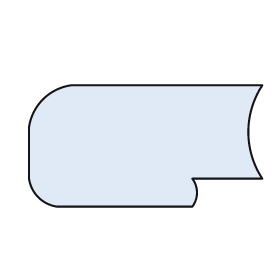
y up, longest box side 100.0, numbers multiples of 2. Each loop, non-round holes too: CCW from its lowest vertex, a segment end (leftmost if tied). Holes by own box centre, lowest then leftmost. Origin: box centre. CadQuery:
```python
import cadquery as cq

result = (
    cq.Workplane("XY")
    .moveTo(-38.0, -26.0)
    .lineTo(20.0, -26.0)
    .threePointArc((22.0, -20.0), (20.0, -14.0))
    .lineTo(50.0, -14.0)
    .threePointArc((44.0, 6.0), (50.0, 26.0))
    .lineTo(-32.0, 26.0)
    .threePointArc((-44.0, 20.0), (-50.0, 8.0))
    .lineTo(-50.0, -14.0)
    .threePointArc((-46.0, -22.0), (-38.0, -26.0))
    .close()
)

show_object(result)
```